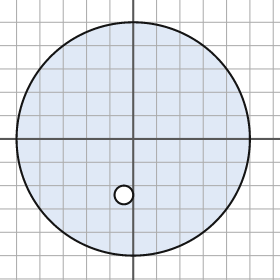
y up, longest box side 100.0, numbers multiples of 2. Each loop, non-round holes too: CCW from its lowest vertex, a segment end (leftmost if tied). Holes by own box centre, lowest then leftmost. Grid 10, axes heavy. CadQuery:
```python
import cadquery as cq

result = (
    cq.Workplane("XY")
    .moveTo(0.0, 0.0)
    .circle(50.0)
    .moveTo(-4.0, -24.0)
    .circle(4.0)
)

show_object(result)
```